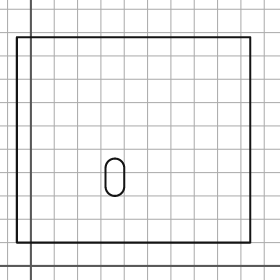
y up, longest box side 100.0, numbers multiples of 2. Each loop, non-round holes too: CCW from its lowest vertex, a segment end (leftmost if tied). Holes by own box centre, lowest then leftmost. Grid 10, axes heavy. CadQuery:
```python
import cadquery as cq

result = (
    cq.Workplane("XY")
    .moveTo(-6.0, 10.0)
    .lineTo(94.0, 10.0)
    .lineTo(94.0, 98.0)
    .lineTo(-6.0, 98.0)
    .close()
    .moveTo(32.0, 34.0)
    .threePointArc((36.0, 30.0), (40.0, 34.0))
    .lineTo(40.0, 42.0)
    .threePointArc((36.0, 46.0), (32.0, 42.0))
    .close()
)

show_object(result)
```